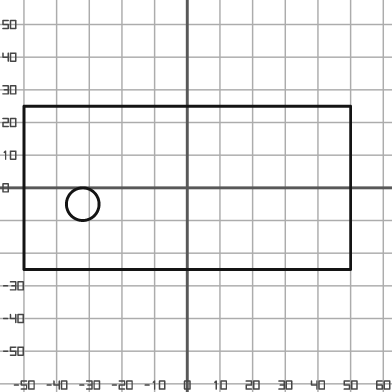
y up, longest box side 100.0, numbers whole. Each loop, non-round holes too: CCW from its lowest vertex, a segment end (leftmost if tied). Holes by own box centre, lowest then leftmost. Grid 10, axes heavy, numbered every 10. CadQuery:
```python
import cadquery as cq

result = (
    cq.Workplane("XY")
    .moveTo(-50.0, -25.0)
    .lineTo(50.0, -25.0)
    .lineTo(50.0, 25.0)
    .lineTo(-50.0, 25.0)
    .close()
    .moveTo(-32.0, -5.0)
    .circle(5.0)
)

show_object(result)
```